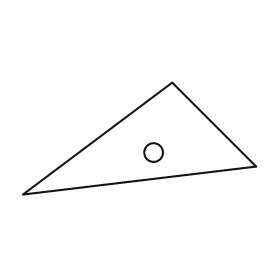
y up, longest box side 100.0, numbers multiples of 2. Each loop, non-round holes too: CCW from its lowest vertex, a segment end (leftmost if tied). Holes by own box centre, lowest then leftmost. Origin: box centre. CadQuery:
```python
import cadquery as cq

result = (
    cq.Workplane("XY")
    .moveTo(-50.0, -24.0)
    .lineTo(50.0, -12.0)
    .lineTo(14.0, 24.0)
    .close()
    .moveTo(6.0, -6.0)
    .circle(4.0)
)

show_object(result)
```